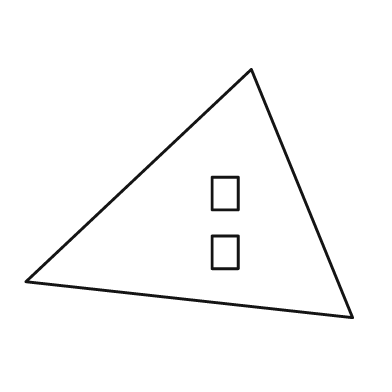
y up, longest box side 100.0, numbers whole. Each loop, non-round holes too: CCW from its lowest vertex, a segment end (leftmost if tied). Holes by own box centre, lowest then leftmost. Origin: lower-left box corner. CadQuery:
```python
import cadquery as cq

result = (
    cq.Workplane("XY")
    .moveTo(100.0, 0.0)
    .lineTo(69.0, 76.0)
    .lineTo(0.0, 11.0)
    .close()
    .moveTo(57.0, 15.0)
    .lineTo(65.0, 15.0)
    .lineTo(65.0, 25.0)
    .lineTo(57.0, 25.0)
    .close()
    .moveTo(57.0, 33.0)
    .lineTo(65.0, 33.0)
    .lineTo(65.0, 43.0)
    .lineTo(57.0, 43.0)
    .close()
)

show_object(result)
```